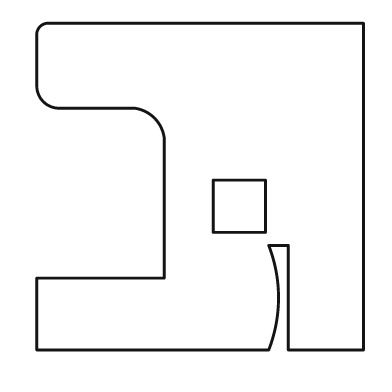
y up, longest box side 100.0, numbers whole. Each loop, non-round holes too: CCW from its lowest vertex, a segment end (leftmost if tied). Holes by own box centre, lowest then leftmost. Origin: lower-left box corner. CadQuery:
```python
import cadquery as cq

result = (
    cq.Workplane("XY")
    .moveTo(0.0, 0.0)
    .lineTo(71.0, 0.0)
    .threePointArc((74.0, 16.0), (71.0, 32.0))
    .lineTo(77.0, 32.0)
    .lineTo(77.0, 0.0)
    .lineTo(100.0, 0.0)
    .lineTo(100.0, 100.0)
    .lineTo(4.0, 100.0)
    .threePointArc((1.0, 99.0), (0.0, 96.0))
    .lineTo(0.0, 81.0)
    .threePointArc((2.0, 76.0), (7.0, 74.0))
    .lineTo(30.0, 74.0)
    .threePointArc((36.0, 71.0), (39.0, 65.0))
    .lineTo(39.0, 22.0)
    .lineTo(0.0, 22.0)
    .close()
    .moveTo(54.0, 36.0)
    .lineTo(70.0, 36.0)
    .lineTo(70.0, 52.0)
    .lineTo(54.0, 52.0)
    .close()
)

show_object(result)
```